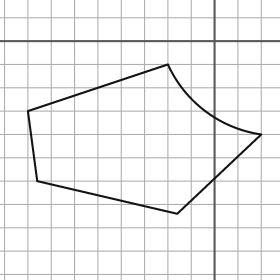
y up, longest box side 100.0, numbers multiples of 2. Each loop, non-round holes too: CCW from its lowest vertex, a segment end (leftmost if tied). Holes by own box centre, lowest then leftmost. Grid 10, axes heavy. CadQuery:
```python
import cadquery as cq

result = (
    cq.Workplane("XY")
    .moveTo(-16.0, -74.0)
    .lineTo(20.0, -40.0)
    .threePointArc((-4.0, -30.0), (-20.0, -10.0))
    .lineTo(-80.0, -30.0)
    .lineTo(-76.0, -60.0)
    .close()
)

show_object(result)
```